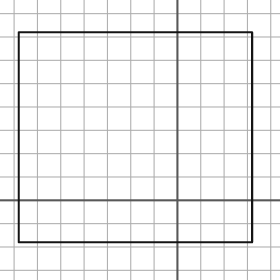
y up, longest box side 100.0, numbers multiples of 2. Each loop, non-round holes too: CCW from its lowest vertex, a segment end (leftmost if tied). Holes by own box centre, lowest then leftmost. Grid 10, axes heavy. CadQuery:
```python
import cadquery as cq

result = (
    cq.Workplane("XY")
    .moveTo(-68.0, -18.0)
    .lineTo(32.0, -18.0)
    .lineTo(32.0, 72.0)
    .lineTo(-68.0, 72.0)
    .close()
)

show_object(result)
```